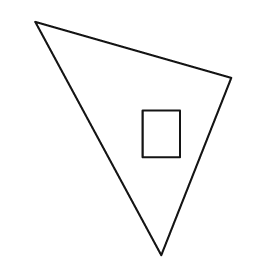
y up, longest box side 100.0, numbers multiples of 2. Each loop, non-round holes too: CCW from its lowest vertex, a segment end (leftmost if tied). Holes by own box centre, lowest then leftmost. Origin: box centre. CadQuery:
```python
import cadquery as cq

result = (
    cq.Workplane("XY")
    .moveTo(12.0, -50.0)
    .lineTo(42.0, 26.0)
    .lineTo(-42.0, 50.0)
    .close()
    .moveTo(4.0, -8.0)
    .lineTo(20.0, -8.0)
    .lineTo(20.0, 12.0)
    .lineTo(4.0, 12.0)
    .close()
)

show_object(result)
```